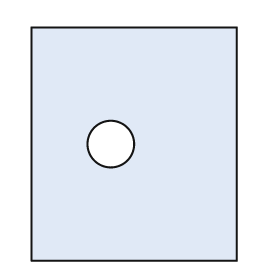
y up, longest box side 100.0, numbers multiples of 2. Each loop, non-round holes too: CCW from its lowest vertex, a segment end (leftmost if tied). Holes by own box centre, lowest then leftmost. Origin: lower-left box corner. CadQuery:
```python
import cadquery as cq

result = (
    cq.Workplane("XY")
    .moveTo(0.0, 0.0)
    .lineTo(88.0, 0.0)
    .lineTo(88.0, 100.0)
    .lineTo(0.0, 100.0)
    .close()
    .moveTo(34.0, 50.0)
    .circle(10.0)
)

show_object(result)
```